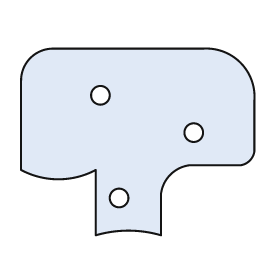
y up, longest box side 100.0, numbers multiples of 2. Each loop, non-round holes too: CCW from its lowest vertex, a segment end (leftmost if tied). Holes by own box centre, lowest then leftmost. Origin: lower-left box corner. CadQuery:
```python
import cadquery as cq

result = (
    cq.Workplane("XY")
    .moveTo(32.0, 0.0)
    .threePointArc((46.0, 2.0), (60.0, 0.0))
    .lineTo(60.0, 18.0)
    .threePointArc((64.0, 26.0), (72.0, 30.0))
    .lineTo(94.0, 30.0)
    .threePointArc((98.0, 32.0), (100.0, 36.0))
    .lineTo(100.0, 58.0)
    .threePointArc((94.0, 74.0), (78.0, 80.0))
    .lineTo(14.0, 80.0)
    .threePointArc((4.0, 76.0), (0.0, 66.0))
    .lineTo(0.0, 28.0)
    .threePointArc((16.0, 24.0), (32.0, 28.0))
    .close()
    .moveTo(42.0, 16.0)
    .circle(4.0)
    .moveTo(74.0, 44.0)
    .circle(4.0)
    .moveTo(34.0, 60.0)
    .circle(4.0)
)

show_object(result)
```